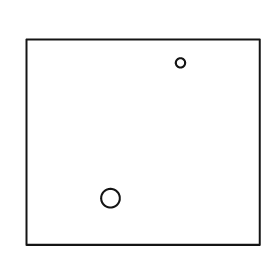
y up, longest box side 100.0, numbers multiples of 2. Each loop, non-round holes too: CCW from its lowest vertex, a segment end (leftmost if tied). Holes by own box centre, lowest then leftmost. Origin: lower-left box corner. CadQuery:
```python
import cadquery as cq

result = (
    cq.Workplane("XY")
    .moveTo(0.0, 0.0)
    .lineTo(100.0, 0.0)
    .lineTo(100.0, 88.0)
    .lineTo(0.0, 88.0)
    .close()
    .moveTo(36.0, 20.0)
    .circle(4.0)
    .moveTo(66.0, 78.0)
    .circle(2.0)
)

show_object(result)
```